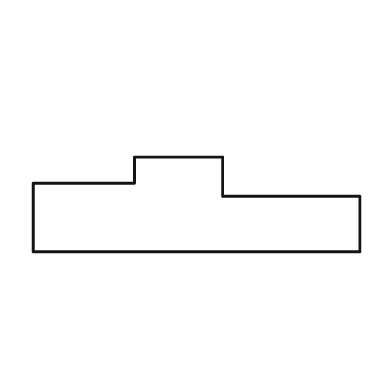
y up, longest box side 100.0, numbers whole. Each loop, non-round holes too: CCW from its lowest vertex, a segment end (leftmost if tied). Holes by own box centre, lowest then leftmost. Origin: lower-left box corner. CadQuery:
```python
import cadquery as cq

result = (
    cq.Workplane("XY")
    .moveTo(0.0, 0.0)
    .lineTo(100.0, 0.0)
    .lineTo(100.0, 17.0)
    .lineTo(58.0, 17.0)
    .lineTo(58.0, 29.0)
    .lineTo(31.0, 29.0)
    .lineTo(31.0, 21.0)
    .lineTo(0.0, 21.0)
    .close()
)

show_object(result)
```